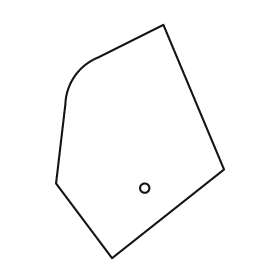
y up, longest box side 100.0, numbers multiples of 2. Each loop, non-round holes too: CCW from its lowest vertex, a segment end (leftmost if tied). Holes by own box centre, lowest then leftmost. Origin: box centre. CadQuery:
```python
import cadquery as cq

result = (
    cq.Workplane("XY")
    .moveTo(-12.0, -50.0)
    .lineTo(36.0, -12.0)
    .lineTo(10.0, 50.0)
    .lineTo(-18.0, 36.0)
    .threePointArc((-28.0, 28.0), (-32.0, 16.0))
    .lineTo(-36.0, -18.0)
    .close()
    .moveTo(2.0, -20.0)
    .circle(2.0)
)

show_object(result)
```